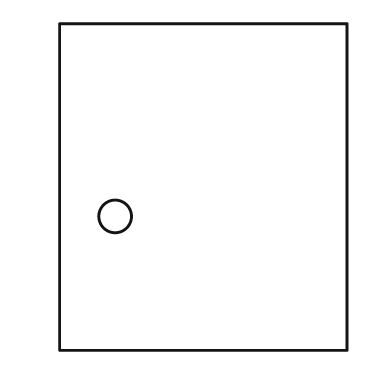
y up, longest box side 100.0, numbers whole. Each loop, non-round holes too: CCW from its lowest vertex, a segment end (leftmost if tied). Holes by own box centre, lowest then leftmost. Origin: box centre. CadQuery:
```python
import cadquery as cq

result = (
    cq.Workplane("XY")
    .moveTo(-44.0, -50.0)
    .lineTo(44.0, -50.0)
    .lineTo(44.0, 50.0)
    .lineTo(-44.0, 50.0)
    .close()
    .moveTo(-27.0, -9.0)
    .circle(5.0)
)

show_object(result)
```